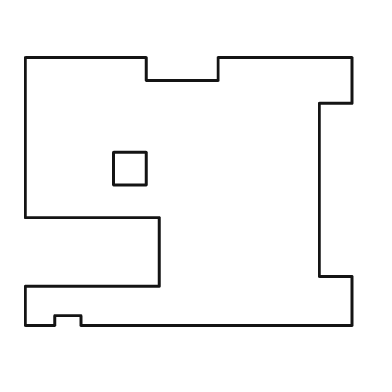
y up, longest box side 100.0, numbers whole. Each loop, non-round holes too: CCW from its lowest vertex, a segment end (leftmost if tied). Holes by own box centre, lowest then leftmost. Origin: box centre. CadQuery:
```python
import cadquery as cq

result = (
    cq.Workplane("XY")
    .moveTo(-50.0, -41.0)
    .lineTo(-41.0, -41.0)
    .lineTo(-41.0, -38.0)
    .lineTo(-33.0, -38.0)
    .lineTo(-33.0, -41.0)
    .lineTo(50.0, -41.0)
    .lineTo(50.0, -26.0)
    .lineTo(40.0, -26.0)
    .lineTo(40.0, 27.0)
    .lineTo(50.0, 27.0)
    .lineTo(50.0, 41.0)
    .lineTo(9.0, 41.0)
    .lineTo(9.0, 34.0)
    .lineTo(-13.0, 34.0)
    .lineTo(-13.0, 41.0)
    .lineTo(-50.0, 41.0)
    .lineTo(-50.0, -8.0)
    .lineTo(-9.0, -8.0)
    .lineTo(-9.0, -29.0)
    .lineTo(-50.0, -29.0)
    .close()
    .moveTo(-23.0, 2.0)
    .lineTo(-13.0, 2.0)
    .lineTo(-13.0, 12.0)
    .lineTo(-23.0, 12.0)
    .close()
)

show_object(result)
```